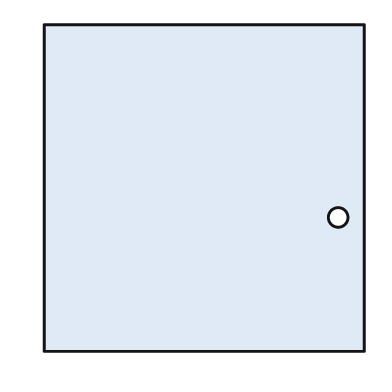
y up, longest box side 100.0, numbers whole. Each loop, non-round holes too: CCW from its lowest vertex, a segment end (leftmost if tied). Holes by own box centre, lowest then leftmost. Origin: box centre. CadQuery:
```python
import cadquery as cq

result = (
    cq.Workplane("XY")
    .moveTo(-49.0, -50.0)
    .lineTo(49.0, -50.0)
    .lineTo(49.0, 50.0)
    .lineTo(-49.0, 50.0)
    .close()
    .moveTo(41.0, -9.0)
    .circle(3.0)
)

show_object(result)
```